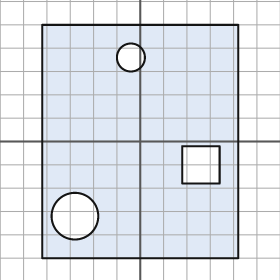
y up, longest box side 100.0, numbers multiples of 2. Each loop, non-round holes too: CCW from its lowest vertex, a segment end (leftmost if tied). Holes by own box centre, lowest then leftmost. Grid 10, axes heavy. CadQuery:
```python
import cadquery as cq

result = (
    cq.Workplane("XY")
    .moveTo(-42.0, -50.0)
    .lineTo(42.0, -50.0)
    .lineTo(42.0, 50.0)
    .lineTo(-42.0, 50.0)
    .close()
    .moveTo(-28.0, -32.0)
    .circle(10.0)
    .moveTo(18.0, -18.0)
    .lineTo(34.0, -18.0)
    .lineTo(34.0, -2.0)
    .lineTo(18.0, -2.0)
    .close()
    .moveTo(-4.0, 36.0)
    .circle(6.0)
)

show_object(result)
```